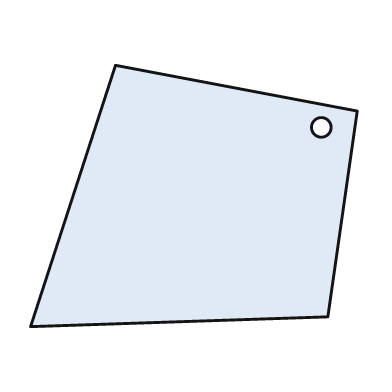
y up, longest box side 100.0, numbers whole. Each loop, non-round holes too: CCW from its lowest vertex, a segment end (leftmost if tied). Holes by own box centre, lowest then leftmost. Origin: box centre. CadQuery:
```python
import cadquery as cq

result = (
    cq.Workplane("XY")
    .moveTo(-50.0, -40.0)
    .lineTo(41.0, -37.0)
    .lineTo(50.0, 26.0)
    .lineTo(-24.0, 40.0)
    .close()
    .moveTo(39.0, 21.0)
    .circle(3.0)
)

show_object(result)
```